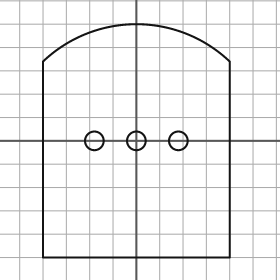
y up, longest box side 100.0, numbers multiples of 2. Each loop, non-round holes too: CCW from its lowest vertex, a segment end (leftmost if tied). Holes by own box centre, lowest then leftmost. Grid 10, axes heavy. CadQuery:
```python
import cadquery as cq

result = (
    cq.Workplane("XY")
    .moveTo(-40.0, -50.0)
    .lineTo(40.0, -50.0)
    .lineTo(40.0, 34.0)
    .threePointArc((0.0, 50.0), (-40.0, 34.0))
    .close()
    .moveTo(-18.0, 0.0)
    .circle(4.0)
    .moveTo(0.0, 0.0)
    .circle(4.0)
    .moveTo(18.0, 0.0)
    .circle(4.0)
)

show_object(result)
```